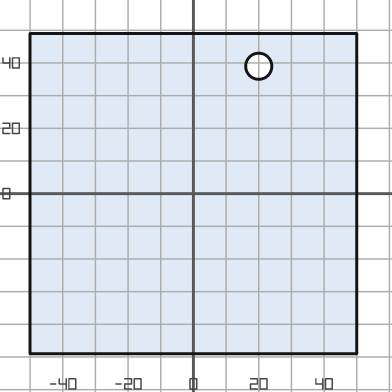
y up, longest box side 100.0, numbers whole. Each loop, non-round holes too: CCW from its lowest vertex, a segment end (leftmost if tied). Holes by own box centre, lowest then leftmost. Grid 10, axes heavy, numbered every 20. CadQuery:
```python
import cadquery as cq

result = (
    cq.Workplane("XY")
    .moveTo(-50.0, -49.0)
    .lineTo(50.0, -49.0)
    .lineTo(50.0, 49.0)
    .lineTo(-50.0, 49.0)
    .close()
    .moveTo(20.0, 39.0)
    .circle(4.0)
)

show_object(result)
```